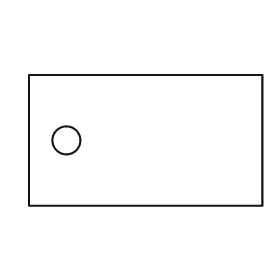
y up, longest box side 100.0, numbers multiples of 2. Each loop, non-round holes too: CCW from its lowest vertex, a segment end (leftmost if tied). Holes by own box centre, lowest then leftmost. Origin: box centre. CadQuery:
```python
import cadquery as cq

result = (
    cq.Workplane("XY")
    .moveTo(-50.0, -28.0)
    .lineTo(50.0, -28.0)
    .lineTo(50.0, 28.0)
    .lineTo(-50.0, 28.0)
    .close()
    .moveTo(-34.0, 0.0)
    .circle(6.0)
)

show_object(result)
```